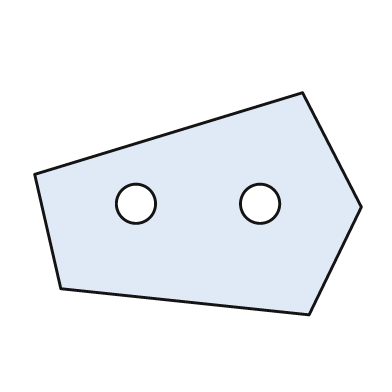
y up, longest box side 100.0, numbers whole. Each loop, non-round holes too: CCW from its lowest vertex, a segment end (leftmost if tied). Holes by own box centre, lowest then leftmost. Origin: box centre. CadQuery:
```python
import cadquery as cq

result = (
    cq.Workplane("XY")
    .moveTo(34.0, -34.0)
    .lineTo(50.0, -1.0)
    .lineTo(32.0, 34.0)
    .lineTo(-50.0, 9.0)
    .lineTo(-42.0, -26.0)
    .close()
    .moveTo(-19.0, 0.0)
    .circle(6.0)
    .moveTo(19.0, 0.0)
    .circle(6.0)
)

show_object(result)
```